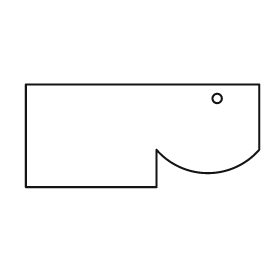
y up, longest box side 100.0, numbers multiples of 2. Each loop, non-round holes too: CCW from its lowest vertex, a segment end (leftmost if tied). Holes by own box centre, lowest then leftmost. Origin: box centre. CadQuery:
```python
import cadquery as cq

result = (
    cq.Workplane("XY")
    .moveTo(-50.0, -22.0)
    .lineTo(6.0, -22.0)
    .lineTo(6.0, -6.0)
    .threePointArc((28.0, -16.0), (50.0, -6.0))
    .lineTo(50.0, 22.0)
    .lineTo(-50.0, 22.0)
    .close()
    .moveTo(32.0, 16.0)
    .circle(2.0)
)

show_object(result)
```